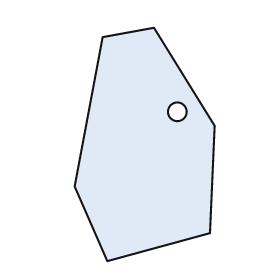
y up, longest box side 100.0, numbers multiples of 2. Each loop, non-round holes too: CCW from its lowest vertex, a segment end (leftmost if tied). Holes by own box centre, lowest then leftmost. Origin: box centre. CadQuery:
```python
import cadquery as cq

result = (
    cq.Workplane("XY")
    .moveTo(-16.0, -50.0)
    .lineTo(28.0, -38.0)
    .lineTo(30.0, 8.0)
    .lineTo(4.0, 50.0)
    .lineTo(-18.0, 46.0)
    .lineTo(-30.0, -18.0)
    .close()
    .moveTo(14.0, 14.0)
    .circle(4.0)
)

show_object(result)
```